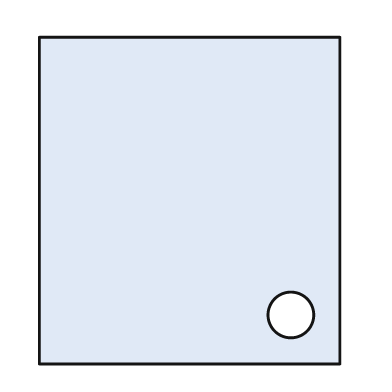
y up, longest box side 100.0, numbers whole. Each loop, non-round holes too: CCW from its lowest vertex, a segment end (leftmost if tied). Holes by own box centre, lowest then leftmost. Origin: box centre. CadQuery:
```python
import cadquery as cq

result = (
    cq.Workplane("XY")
    .moveTo(-46.0, -50.0)
    .lineTo(46.0, -50.0)
    .lineTo(46.0, 50.0)
    .lineTo(-46.0, 50.0)
    .close()
    .moveTo(31.0, -35.0)
    .circle(7.0)
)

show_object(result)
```